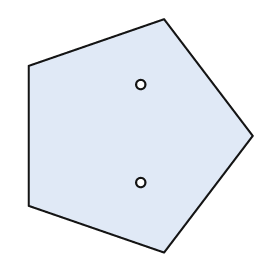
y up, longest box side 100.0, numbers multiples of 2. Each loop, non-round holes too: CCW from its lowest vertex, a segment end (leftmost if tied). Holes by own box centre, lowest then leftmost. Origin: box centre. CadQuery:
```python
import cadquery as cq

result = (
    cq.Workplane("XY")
    .moveTo(10.0, -50.0)
    .lineTo(48.0, 0.0)
    .lineTo(10.0, 50.0)
    .lineTo(-48.0, 30.0)
    .lineTo(-48.0, -30.0)
    .close()
    .moveTo(0.0, -20.0)
    .circle(2.0)
    .moveTo(0.0, 22.0)
    .circle(2.0)
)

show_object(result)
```